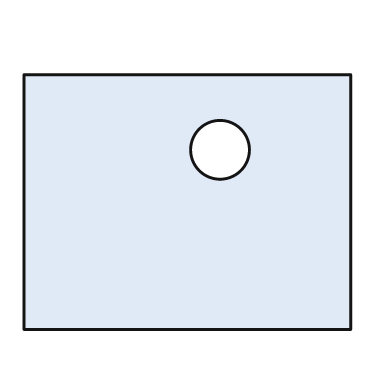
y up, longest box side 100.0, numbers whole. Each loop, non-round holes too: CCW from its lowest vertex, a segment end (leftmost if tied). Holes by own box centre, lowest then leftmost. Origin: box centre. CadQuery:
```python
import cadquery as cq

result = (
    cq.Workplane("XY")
    .moveTo(-50.0, -39.0)
    .lineTo(50.0, -39.0)
    .lineTo(50.0, 39.0)
    .lineTo(-50.0, 39.0)
    .close()
    .moveTo(10.0, 16.0)
    .circle(9.0)
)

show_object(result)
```